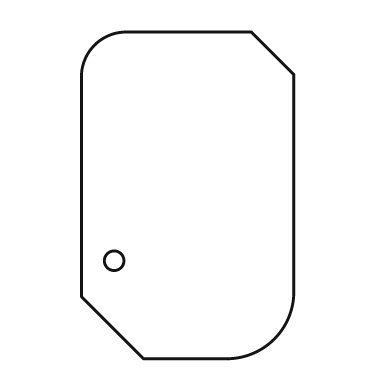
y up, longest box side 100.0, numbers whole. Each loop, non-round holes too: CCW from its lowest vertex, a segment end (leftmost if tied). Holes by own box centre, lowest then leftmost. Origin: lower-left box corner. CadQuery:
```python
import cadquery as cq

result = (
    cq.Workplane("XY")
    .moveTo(19.0, 0.0)
    .lineTo(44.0, 0.0)
    .threePointArc((59.0, 6.0), (65.0, 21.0))
    .lineTo(65.0, 87.0)
    .lineTo(52.0, 100.0)
    .lineTo(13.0, 100.0)
    .threePointArc((4.0, 96.0), (0.0, 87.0))
    .lineTo(0.0, 19.0)
    .close()
    .moveTo(10.0, 30.0)
    .circle(3.0)
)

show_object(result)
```